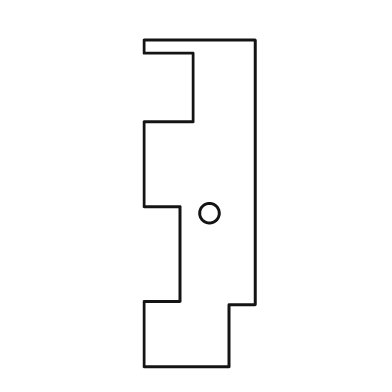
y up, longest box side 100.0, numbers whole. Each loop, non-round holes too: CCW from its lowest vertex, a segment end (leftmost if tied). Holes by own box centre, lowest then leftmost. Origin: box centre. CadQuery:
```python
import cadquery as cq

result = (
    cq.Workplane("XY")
    .moveTo(-17.0, -50.0)
    .lineTo(9.0, -50.0)
    .lineTo(9.0, -31.0)
    .lineTo(17.0, -31.0)
    .lineTo(17.0, 50.0)
    .lineTo(-17.0, 50.0)
    .lineTo(-17.0, 46.0)
    .lineTo(-2.0, 46.0)
    .lineTo(-2.0, 25.0)
    .lineTo(-17.0, 25.0)
    .lineTo(-17.0, -1.0)
    .lineTo(-6.0, -1.0)
    .lineTo(-6.0, -30.0)
    .lineTo(-17.0, -30.0)
    .close()
    .moveTo(3.0, -3.0)
    .circle(3.0)
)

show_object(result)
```